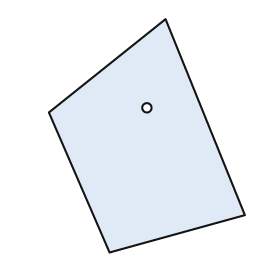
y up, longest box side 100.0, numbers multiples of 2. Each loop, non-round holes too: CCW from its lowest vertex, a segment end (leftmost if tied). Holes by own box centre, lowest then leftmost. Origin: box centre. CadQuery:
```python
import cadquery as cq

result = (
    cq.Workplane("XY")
    .moveTo(-16.0, -50.0)
    .lineTo(42.0, -34.0)
    .lineTo(8.0, 50.0)
    .lineTo(-42.0, 10.0)
    .close()
    .moveTo(0.0, 12.0)
    .circle(2.0)
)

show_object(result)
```